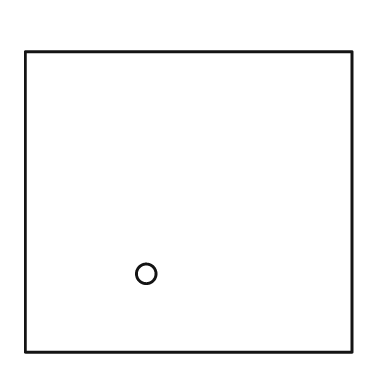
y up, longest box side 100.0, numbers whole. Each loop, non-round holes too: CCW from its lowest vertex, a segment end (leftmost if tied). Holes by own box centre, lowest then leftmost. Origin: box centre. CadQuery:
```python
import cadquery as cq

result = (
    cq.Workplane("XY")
    .moveTo(-50.0, -46.0)
    .lineTo(50.0, -46.0)
    .lineTo(50.0, 46.0)
    .lineTo(-50.0, 46.0)
    .close()
    .moveTo(-13.0, -22.0)
    .circle(3.0)
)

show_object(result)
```